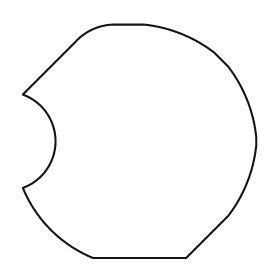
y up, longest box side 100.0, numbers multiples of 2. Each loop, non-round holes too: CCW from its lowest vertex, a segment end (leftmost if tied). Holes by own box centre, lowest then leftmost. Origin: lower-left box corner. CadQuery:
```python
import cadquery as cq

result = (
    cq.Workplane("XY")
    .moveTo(30.0, 0.0)
    .lineTo(70.0, 0.0)
    .lineTo(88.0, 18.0)
    .threePointArc((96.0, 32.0), (100.0, 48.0))
    .lineTo(100.0, 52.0)
    .threePointArc((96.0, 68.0), (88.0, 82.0))
    .lineTo(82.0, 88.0)
    .threePointArc((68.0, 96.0), (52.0, 100.0))
    .lineTo(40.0, 100.0)
    .threePointArc((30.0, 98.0), (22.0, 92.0))
    .lineTo(0.0, 70.0)
    .threePointArc((14.0, 50.0), (0.0, 30.0))
    .threePointArc((12.0, 12.0), (30.0, 0.0))
    .close()
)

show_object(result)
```